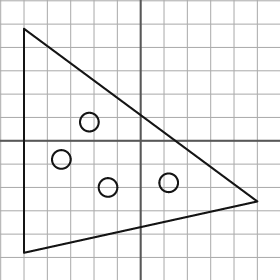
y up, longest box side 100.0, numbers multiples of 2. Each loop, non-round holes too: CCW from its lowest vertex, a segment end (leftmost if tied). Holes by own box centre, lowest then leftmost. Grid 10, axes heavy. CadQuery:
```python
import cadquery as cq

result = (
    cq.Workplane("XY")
    .moveTo(-50.0, -48.0)
    .lineTo(50.0, -26.0)
    .lineTo(-50.0, 48.0)
    .close()
    .moveTo(-14.0, -20.0)
    .circle(4.0)
    .moveTo(12.0, -18.0)
    .circle(4.0)
    .moveTo(-34.0, -8.0)
    .circle(4.0)
    .moveTo(-22.0, 8.0)
    .circle(4.0)
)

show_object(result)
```